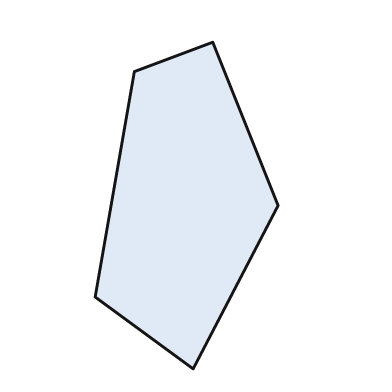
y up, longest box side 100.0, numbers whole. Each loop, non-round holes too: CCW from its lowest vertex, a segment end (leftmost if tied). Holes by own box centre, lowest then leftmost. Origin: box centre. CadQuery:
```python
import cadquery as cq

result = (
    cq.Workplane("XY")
    .moveTo(2.0, -50.0)
    .lineTo(28.0, 0.0)
    .lineTo(8.0, 50.0)
    .lineTo(-16.0, 41.0)
    .lineTo(-28.0, -28.0)
    .close()
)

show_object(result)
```